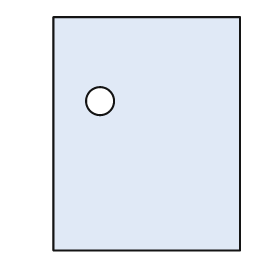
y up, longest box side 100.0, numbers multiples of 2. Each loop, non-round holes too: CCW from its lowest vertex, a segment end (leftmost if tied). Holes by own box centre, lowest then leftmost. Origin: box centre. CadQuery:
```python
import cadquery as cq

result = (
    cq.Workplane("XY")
    .moveTo(-40.0, -50.0)
    .lineTo(40.0, -50.0)
    .lineTo(40.0, 50.0)
    .lineTo(-40.0, 50.0)
    .close()
    .moveTo(-20.0, 14.0)
    .circle(6.0)
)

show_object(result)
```